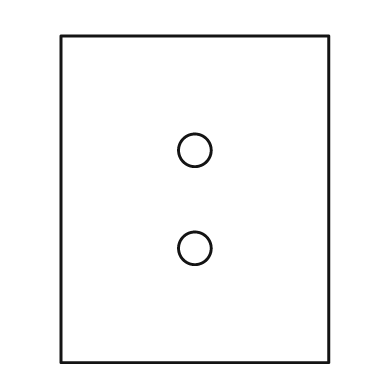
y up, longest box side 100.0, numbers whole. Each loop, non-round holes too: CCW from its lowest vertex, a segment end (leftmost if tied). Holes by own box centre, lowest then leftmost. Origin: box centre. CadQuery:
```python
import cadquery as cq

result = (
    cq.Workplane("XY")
    .moveTo(-41.0, -50.0)
    .lineTo(41.0, -50.0)
    .lineTo(41.0, 50.0)
    .lineTo(-41.0, 50.0)
    .close()
    .moveTo(0.0, -15.0)
    .circle(5.0)
    .moveTo(0.0, 15.0)
    .circle(5.0)
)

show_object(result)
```